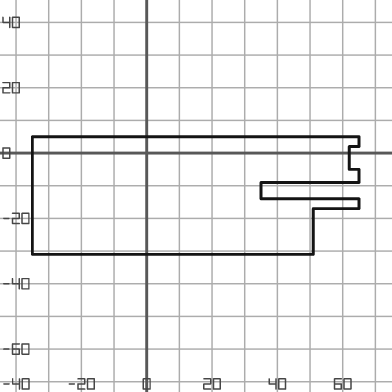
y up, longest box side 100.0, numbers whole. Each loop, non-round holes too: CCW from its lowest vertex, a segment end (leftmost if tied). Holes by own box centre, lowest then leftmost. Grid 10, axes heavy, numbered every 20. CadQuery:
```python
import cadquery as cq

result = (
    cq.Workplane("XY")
    .moveTo(-35.0, -31.0)
    .lineTo(51.0, -31.0)
    .lineTo(51.0, -17.0)
    .lineTo(65.0, -17.0)
    .lineTo(65.0, -14.0)
    .lineTo(35.0, -14.0)
    .lineTo(35.0, -9.0)
    .lineTo(65.0, -9.0)
    .lineTo(65.0, -5.0)
    .lineTo(62.0, -5.0)
    .lineTo(62.0, 2.0)
    .lineTo(65.0, 2.0)
    .lineTo(65.0, 5.0)
    .lineTo(-35.0, 5.0)
    .close()
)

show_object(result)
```